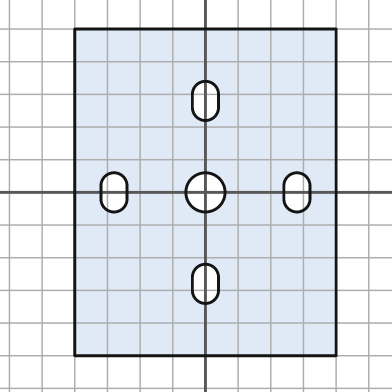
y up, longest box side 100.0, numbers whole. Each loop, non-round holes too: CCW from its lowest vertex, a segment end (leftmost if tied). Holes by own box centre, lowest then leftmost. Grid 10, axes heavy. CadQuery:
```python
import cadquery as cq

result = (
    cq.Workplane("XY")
    .moveTo(-40.0, -50.0)
    .lineTo(40.0, -50.0)
    .lineTo(40.0, 50.0)
    .lineTo(-40.0, 50.0)
    .close()
    .moveTo(-4.0, -30.0)
    .threePointArc((0.0, -34.0), (4.0, -30.0))
    .lineTo(4.0, -26.0)
    .threePointArc((0.0, -22.0), (-4.0, -26.0))
    .close()
    .moveTo(-32.0, -2.0)
    .threePointArc((-28.0, -6.0), (-24.0, -2.0))
    .lineTo(-24.0, 2.0)
    .threePointArc((-28.0, 6.0), (-32.0, 2.0))
    .close()
    .moveTo(0.0, 0.0)
    .circle(6.0)
    .moveTo(24.0, -2.0)
    .threePointArc((28.0, -6.0), (32.0, -2.0))
    .lineTo(32.0, 2.0)
    .threePointArc((28.0, 6.0), (24.0, 2.0))
    .close()
    .moveTo(-4.0, 26.0)
    .threePointArc((0.0, 22.0), (4.0, 26.0))
    .lineTo(4.0, 30.0)
    .threePointArc((0.0, 34.0), (-4.0, 30.0))
    .close()
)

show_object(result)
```